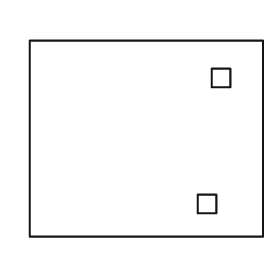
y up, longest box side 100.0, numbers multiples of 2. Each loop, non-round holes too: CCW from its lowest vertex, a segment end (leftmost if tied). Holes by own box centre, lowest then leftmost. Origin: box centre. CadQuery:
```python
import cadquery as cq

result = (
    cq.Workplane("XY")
    .moveTo(-50.0, -42.0)
    .lineTo(50.0, -42.0)
    .lineTo(50.0, 42.0)
    .lineTo(-50.0, 42.0)
    .close()
    .moveTo(22.0, -32.0)
    .lineTo(30.0, -32.0)
    .lineTo(30.0, -24.0)
    .lineTo(22.0, -24.0)
    .close()
    .moveTo(28.0, 22.0)
    .lineTo(36.0, 22.0)
    .lineTo(36.0, 30.0)
    .lineTo(28.0, 30.0)
    .close()
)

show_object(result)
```